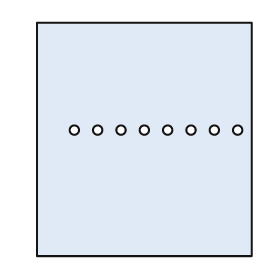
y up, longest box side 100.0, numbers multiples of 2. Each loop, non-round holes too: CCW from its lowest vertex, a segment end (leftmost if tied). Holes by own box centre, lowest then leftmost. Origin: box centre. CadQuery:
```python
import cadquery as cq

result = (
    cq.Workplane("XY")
    .moveTo(-46.0, -50.0)
    .lineTo(46.0, -50.0)
    .lineTo(46.0, 50.0)
    .lineTo(-46.0, 50.0)
    .close()
    .moveTo(-30.0, 4.0)
    .circle(2.0)
    .moveTo(-20.0, 4.0)
    .circle(2.0)
    .moveTo(-10.0, 4.0)
    .circle(2.0)
    .moveTo(0.0, 4.0)
    .circle(2.0)
    .moveTo(10.0, 4.0)
    .circle(2.0)
    .moveTo(20.0, 4.0)
    .circle(2.0)
    .moveTo(30.0, 4.0)
    .circle(2.0)
    .moveTo(40.0, 4.0)
    .circle(2.0)
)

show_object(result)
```